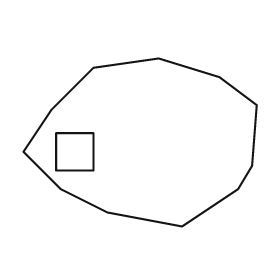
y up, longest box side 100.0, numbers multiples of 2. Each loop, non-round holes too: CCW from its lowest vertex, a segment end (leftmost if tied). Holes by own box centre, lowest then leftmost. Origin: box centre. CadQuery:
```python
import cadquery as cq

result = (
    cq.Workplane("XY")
    .moveTo(18.0, -36.0)
    .lineTo(42.0, -20.0)
    .lineTo(48.0, -10.0)
    .lineTo(50.0, 16.0)
    .lineTo(34.0, 28.0)
    .lineTo(8.0, 36.0)
    .lineTo(-20.0, 32.0)
    .lineTo(-38.0, 14.0)
    .lineTo(-50.0, -4.0)
    .lineTo(-34.0, -20.0)
    .lineTo(-14.0, -30.0)
    .close()
    .moveTo(-36.0, -12.0)
    .lineTo(-20.0, -12.0)
    .lineTo(-20.0, 4.0)
    .lineTo(-36.0, 4.0)
    .close()
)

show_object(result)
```